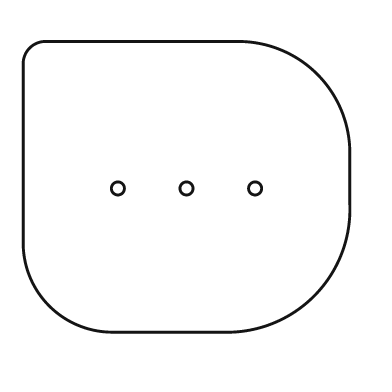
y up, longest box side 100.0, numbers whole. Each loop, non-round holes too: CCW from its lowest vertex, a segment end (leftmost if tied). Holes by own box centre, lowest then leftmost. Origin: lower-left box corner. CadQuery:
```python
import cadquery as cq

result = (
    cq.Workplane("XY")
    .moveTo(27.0, 0.0)
    .lineTo(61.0, 0.0)
    .threePointArc((89.0, 11.0), (100.0, 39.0))
    .lineTo(100.0, 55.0)
    .threePointArc((90.0, 79.0), (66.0, 89.0))
    .lineTo(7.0, 89.0)
    .threePointArc((2.0, 87.0), (0.0, 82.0))
    .lineTo(0.0, 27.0)
    .threePointArc((8.0, 8.0), (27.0, 0.0))
    .close()
    .moveTo(29.0, 44.0)
    .circle(2.0)
    .moveTo(50.0, 44.0)
    .circle(2.0)
    .moveTo(71.0, 44.0)
    .circle(2.0)
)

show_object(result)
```